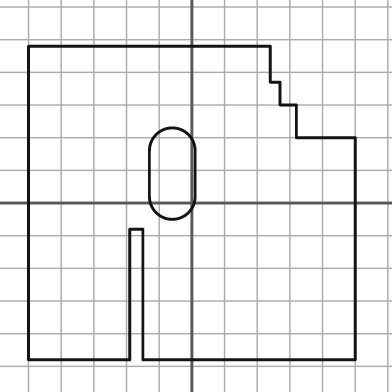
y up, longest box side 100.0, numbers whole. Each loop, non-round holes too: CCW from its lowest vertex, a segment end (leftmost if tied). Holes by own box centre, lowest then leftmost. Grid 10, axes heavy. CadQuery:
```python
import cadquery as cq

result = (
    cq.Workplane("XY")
    .moveTo(-50.0, -48.0)
    .lineTo(-19.0, -48.0)
    .lineTo(-19.0, -8.0)
    .lineTo(-15.0, -8.0)
    .lineTo(-15.0, -48.0)
    .lineTo(50.0, -48.0)
    .lineTo(50.0, 20.0)
    .lineTo(32.0, 20.0)
    .lineTo(32.0, 30.0)
    .lineTo(27.0, 30.0)
    .lineTo(27.0, 37.0)
    .lineTo(24.0, 37.0)
    .lineTo(24.0, 48.0)
    .lineTo(-50.0, 48.0)
    .close()
    .moveTo(-13.0, 2.0)
    .threePointArc((-6.0, -5.0), (1.0, 2.0))
    .lineTo(1.0, 16.0)
    .threePointArc((-6.0, 23.0), (-13.0, 16.0))
    .close()
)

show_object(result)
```